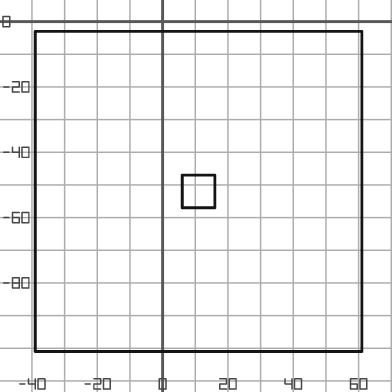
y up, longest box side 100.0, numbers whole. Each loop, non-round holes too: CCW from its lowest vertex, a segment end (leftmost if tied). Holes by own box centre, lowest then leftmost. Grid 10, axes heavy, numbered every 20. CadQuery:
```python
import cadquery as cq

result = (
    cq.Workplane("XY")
    .moveTo(-39.0, -101.0)
    .lineTo(61.0, -101.0)
    .lineTo(61.0, -3.0)
    .lineTo(-39.0, -3.0)
    .close()
    .moveTo(6.0, -57.0)
    .lineTo(16.0, -57.0)
    .lineTo(16.0, -47.0)
    .lineTo(6.0, -47.0)
    .close()
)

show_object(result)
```